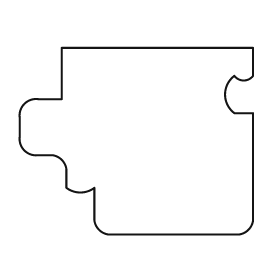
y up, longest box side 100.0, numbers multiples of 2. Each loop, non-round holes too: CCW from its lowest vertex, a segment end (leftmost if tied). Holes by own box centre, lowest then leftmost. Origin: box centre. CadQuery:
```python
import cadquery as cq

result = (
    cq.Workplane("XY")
    .moveTo(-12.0, -40.0)
    .lineTo(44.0, -40.0)
    .threePointArc((48.0, -38.0), (50.0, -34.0))
    .lineTo(50.0, 12.0)
    .lineTo(42.0, 12.0)
    .threePointArc((38.0, 20.0), (42.0, 28.0))
    .threePointArc((46.0, 26.0), (50.0, 28.0))
    .lineTo(50.0, 40.0)
    .lineTo(-32.0, 40.0)
    .lineTo(-32.0, 18.0)
    .lineTo(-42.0, 18.0)
    .threePointArc((-48.0, 16.0), (-50.0, 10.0))
    .lineTo(-50.0, 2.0)
    .threePointArc((-48.0, -4.0), (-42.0, -6.0))
    .lineTo(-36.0, -6.0)
    .threePointArc((-32.0, -8.0), (-30.0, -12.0))
    .lineTo(-30.0, -20.0)
    .threePointArc((-24.0, -22.0), (-18.0, -20.0))
    .lineTo(-18.0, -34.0)
    .threePointArc((-16.0, -38.0), (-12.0, -40.0))
    .close()
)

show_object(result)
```